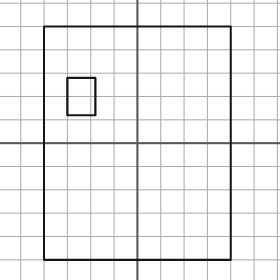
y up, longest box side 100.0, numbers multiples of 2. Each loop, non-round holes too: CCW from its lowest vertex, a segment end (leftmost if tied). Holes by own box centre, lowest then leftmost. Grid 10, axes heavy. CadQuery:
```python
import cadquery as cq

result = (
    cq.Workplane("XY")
    .moveTo(-40.0, -50.0)
    .lineTo(40.0, -50.0)
    .lineTo(40.0, 50.0)
    .lineTo(-40.0, 50.0)
    .close()
    .moveTo(-30.0, 12.0)
    .lineTo(-18.0, 12.0)
    .lineTo(-18.0, 28.0)
    .lineTo(-30.0, 28.0)
    .close()
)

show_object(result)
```